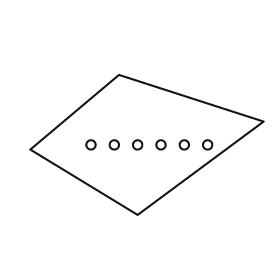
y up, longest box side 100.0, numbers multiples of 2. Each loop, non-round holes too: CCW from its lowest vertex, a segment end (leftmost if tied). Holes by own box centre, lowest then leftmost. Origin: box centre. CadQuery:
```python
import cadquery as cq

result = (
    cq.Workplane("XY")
    .moveTo(-4.0, -30.0)
    .lineTo(50.0, 10.0)
    .lineTo(-12.0, 30.0)
    .lineTo(-50.0, -2.0)
    .close()
    .moveTo(-24.0, 0.0)
    .circle(2.0)
    .moveTo(-14.0, 0.0)
    .circle(2.0)
    .moveTo(-4.0, 0.0)
    .circle(2.0)
    .moveTo(6.0, 0.0)
    .circle(2.0)
    .moveTo(16.0, 0.0)
    .circle(2.0)
    .moveTo(26.0, 0.0)
    .circle(2.0)
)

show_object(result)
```